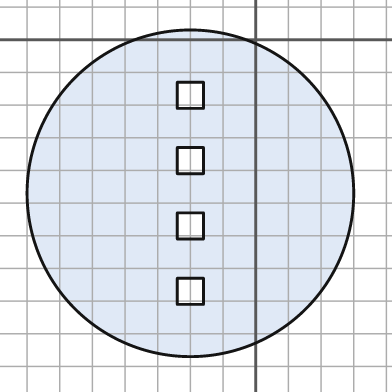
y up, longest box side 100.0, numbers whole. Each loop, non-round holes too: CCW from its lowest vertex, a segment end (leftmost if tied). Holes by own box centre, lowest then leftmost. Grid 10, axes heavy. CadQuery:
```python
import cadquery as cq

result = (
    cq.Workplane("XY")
    .moveTo(-20.0, -47.0)
    .circle(50.0)
    .moveTo(-24.0, -81.0)
    .lineTo(-16.0, -81.0)
    .lineTo(-16.0, -73.0)
    .lineTo(-24.0, -73.0)
    .close()
    .moveTo(-24.0, -61.0)
    .lineTo(-16.0, -61.0)
    .lineTo(-16.0, -53.0)
    .lineTo(-24.0, -53.0)
    .close()
    .moveTo(-24.0, -41.0)
    .lineTo(-16.0, -41.0)
    .lineTo(-16.0, -33.0)
    .lineTo(-24.0, -33.0)
    .close()
    .moveTo(-24.0, -21.0)
    .lineTo(-16.0, -21.0)
    .lineTo(-16.0, -13.0)
    .lineTo(-24.0, -13.0)
    .close()
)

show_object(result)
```